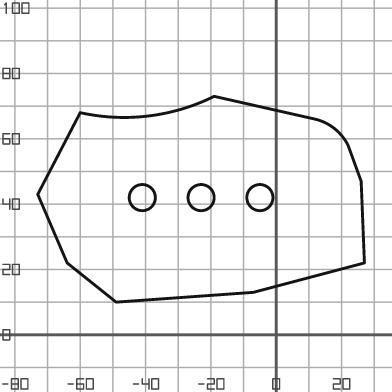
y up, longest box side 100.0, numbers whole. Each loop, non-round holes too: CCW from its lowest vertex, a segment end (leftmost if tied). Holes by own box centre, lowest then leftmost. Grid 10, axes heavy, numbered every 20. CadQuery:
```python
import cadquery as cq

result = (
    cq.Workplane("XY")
    .moveTo(-49.0, 10.0)
    .lineTo(-7.0, 13.0)
    .lineTo(27.0, 22.0)
    .lineTo(26.0, 47.0)
    .lineTo(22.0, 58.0)
    .threePointArc((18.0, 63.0), (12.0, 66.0))
    .lineTo(-19.0, 73.0)
    .threePointArc((-39.0, 67.0), (-60.0, 68.0))
    .lineTo(-73.0, 43.0)
    .lineTo(-64.0, 22.0)
    .close()
    .moveTo(-41.0, 42.0)
    .circle(4.0)
    .moveTo(-23.0, 42.0)
    .circle(4.0)
    .moveTo(-5.0, 42.0)
    .circle(4.0)
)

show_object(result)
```